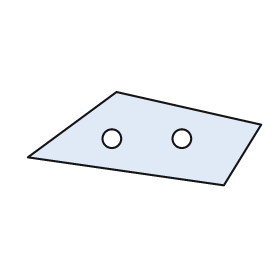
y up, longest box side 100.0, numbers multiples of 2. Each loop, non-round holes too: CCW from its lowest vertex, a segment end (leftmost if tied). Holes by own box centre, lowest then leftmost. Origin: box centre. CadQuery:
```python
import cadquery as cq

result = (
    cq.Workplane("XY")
    .moveTo(34.0, -20.0)
    .lineTo(50.0, 6.0)
    .lineTo(-12.0, 20.0)
    .lineTo(-50.0, -8.0)
    .close()
    .moveTo(-14.0, 0.0)
    .circle(4.0)
    .moveTo(16.0, 0.0)
    .circle(4.0)
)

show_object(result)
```